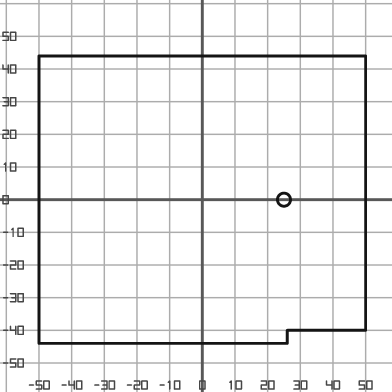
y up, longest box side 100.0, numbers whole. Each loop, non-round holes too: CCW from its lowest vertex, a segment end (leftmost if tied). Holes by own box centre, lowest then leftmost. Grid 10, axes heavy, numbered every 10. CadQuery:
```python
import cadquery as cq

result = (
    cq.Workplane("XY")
    .moveTo(-50.0, -44.0)
    .lineTo(26.0, -44.0)
    .lineTo(26.0, -40.0)
    .lineTo(50.0, -40.0)
    .lineTo(50.0, 44.0)
    .lineTo(-50.0, 44.0)
    .close()
    .moveTo(25.0, 0.0)
    .circle(2.0)
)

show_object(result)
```